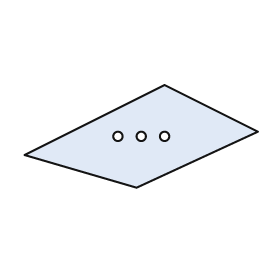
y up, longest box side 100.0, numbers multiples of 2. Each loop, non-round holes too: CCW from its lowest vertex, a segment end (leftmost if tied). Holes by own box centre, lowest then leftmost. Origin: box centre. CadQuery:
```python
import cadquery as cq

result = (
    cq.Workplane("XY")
    .moveTo(-2.0, -22.0)
    .lineTo(50.0, 2.0)
    .lineTo(10.0, 22.0)
    .lineTo(-50.0, -8.0)
    .close()
    .moveTo(-10.0, 0.0)
    .circle(2.0)
    .moveTo(0.0, 0.0)
    .circle(2.0)
    .moveTo(10.0, 0.0)
    .circle(2.0)
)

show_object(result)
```